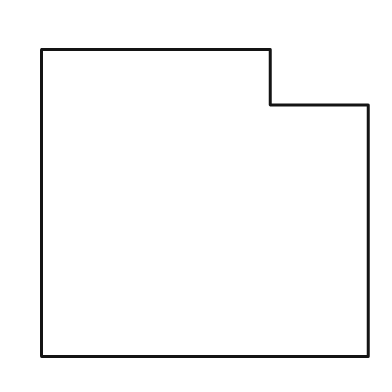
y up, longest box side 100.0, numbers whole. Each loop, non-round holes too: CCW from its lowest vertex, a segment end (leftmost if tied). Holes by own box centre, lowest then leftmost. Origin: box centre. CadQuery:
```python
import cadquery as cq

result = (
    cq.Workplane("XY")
    .moveTo(-50.0, -47.0)
    .lineTo(50.0, -47.0)
    .lineTo(50.0, 30.0)
    .lineTo(20.0, 30.0)
    .lineTo(20.0, 47.0)
    .lineTo(-50.0, 47.0)
    .close()
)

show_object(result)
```